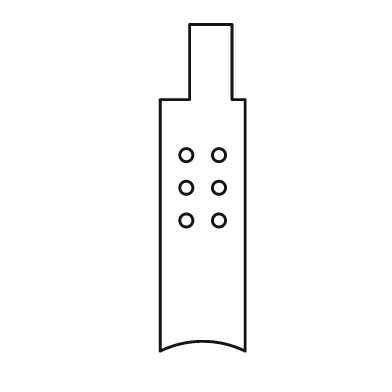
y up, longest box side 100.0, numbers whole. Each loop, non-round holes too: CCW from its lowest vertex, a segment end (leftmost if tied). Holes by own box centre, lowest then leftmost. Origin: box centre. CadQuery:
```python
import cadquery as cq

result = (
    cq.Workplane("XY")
    .moveTo(-13.0, -50.0)
    .threePointArc((0.0, -47.0), (13.0, -50.0))
    .lineTo(13.0, 27.0)
    .lineTo(9.0, 27.0)
    .lineTo(9.0, 50.0)
    .lineTo(-4.0, 50.0)
    .lineTo(-4.0, 27.0)
    .lineTo(-13.0, 27.0)
    .close()
    .moveTo(-5.0, -10.0)
    .circle(2.0)
    .moveTo(5.0, -10.0)
    .circle(2.0)
    .moveTo(-5.0, 0.0)
    .circle(2.0)
    .moveTo(5.0, 0.0)
    .circle(2.0)
    .moveTo(-5.0, 10.0)
    .circle(2.0)
    .moveTo(5.0, 10.0)
    .circle(2.0)
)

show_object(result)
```